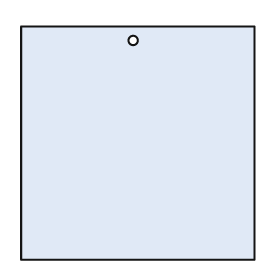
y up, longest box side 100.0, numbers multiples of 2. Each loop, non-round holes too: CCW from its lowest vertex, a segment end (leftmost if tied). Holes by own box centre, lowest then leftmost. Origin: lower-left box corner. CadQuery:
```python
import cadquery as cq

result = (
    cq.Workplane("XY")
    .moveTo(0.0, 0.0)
    .lineTo(100.0, 0.0)
    .lineTo(100.0, 100.0)
    .lineTo(0.0, 100.0)
    .close()
    .moveTo(48.0, 94.0)
    .circle(2.0)
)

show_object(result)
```